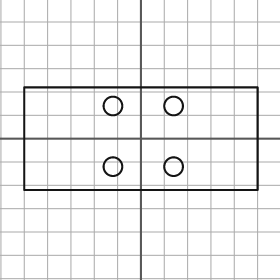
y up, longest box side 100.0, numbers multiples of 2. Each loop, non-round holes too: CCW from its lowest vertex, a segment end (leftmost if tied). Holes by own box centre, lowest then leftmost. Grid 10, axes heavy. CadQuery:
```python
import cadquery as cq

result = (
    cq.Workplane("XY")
    .moveTo(-50.0, -22.0)
    .lineTo(50.0, -22.0)
    .lineTo(50.0, 22.0)
    .lineTo(-50.0, 22.0)
    .close()
    .moveTo(-12.0, -12.0)
    .circle(4.0)
    .moveTo(14.0, -12.0)
    .circle(4.0)
    .moveTo(-12.0, 14.0)
    .circle(4.0)
    .moveTo(14.0, 14.0)
    .circle(4.0)
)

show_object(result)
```